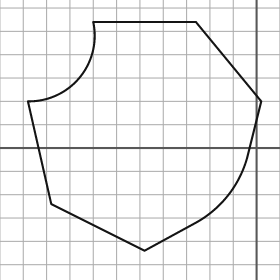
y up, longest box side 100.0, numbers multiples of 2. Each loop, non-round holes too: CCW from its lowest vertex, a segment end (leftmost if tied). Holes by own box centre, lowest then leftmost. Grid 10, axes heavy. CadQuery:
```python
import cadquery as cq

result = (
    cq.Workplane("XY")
    .moveTo(-48.0, -44.0)
    .lineTo(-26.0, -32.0)
    .threePointArc((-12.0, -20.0), (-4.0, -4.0))
    .lineTo(2.0, 20.0)
    .lineTo(-26.0, 54.0)
    .lineTo(-70.0, 54.0)
    .threePointArc((-76.0, 30.0), (-98.0, 20.0))
    .lineTo(-88.0, -24.0)
    .close()
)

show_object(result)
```